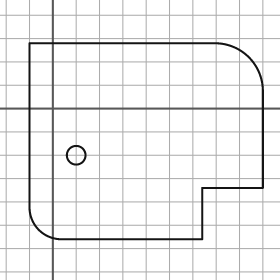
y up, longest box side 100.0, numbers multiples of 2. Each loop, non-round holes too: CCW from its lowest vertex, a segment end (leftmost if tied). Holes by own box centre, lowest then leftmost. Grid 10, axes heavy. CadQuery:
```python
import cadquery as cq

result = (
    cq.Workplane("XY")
    .moveTo(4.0, -56.0)
    .lineTo(64.0, -56.0)
    .lineTo(64.0, -34.0)
    .lineTo(90.0, -34.0)
    .lineTo(90.0, 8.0)
    .threePointArc((84.0, 22.0), (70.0, 28.0))
    .lineTo(-10.0, 28.0)
    .lineTo(-10.0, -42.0)
    .threePointArc((-6.0, -52.0), (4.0, -56.0))
    .close()
    .moveTo(10.0, -20.0)
    .circle(4.0)
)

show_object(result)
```